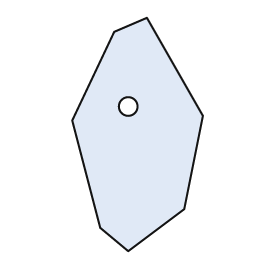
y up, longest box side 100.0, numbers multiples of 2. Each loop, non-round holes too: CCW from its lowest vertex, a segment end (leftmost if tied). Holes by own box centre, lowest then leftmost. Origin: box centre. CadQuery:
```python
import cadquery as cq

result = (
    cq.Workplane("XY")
    .moveTo(-4.0, -50.0)
    .lineTo(20.0, -32.0)
    .lineTo(28.0, 8.0)
    .lineTo(4.0, 50.0)
    .lineTo(-10.0, 44.0)
    .lineTo(-28.0, 6.0)
    .lineTo(-16.0, -40.0)
    .close()
    .moveTo(-4.0, 12.0)
    .circle(4.0)
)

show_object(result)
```